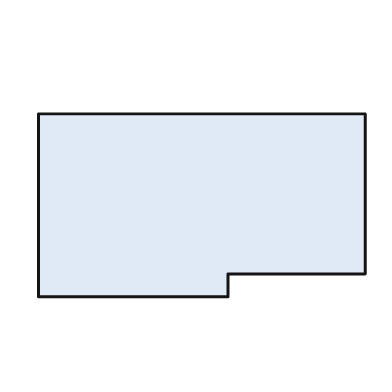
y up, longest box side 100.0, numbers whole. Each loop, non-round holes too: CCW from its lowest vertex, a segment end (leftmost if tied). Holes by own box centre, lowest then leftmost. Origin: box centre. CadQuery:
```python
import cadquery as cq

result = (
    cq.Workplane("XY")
    .moveTo(-50.0, -28.0)
    .lineTo(8.0, -28.0)
    .lineTo(8.0, -21.0)
    .lineTo(50.0, -21.0)
    .lineTo(50.0, 28.0)
    .lineTo(-50.0, 28.0)
    .close()
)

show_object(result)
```